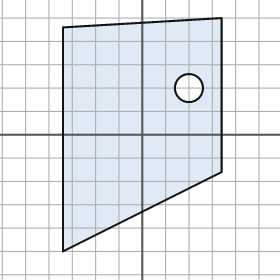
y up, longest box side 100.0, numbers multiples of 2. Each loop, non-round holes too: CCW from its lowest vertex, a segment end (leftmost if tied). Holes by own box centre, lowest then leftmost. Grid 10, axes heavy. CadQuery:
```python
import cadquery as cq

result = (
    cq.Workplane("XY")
    .moveTo(-34.0, -50.0)
    .lineTo(34.0, -16.0)
    .lineTo(34.0, 50.0)
    .lineTo(-34.0, 46.0)
    .close()
    .moveTo(20.0, 20.0)
    .circle(6.0)
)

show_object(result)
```